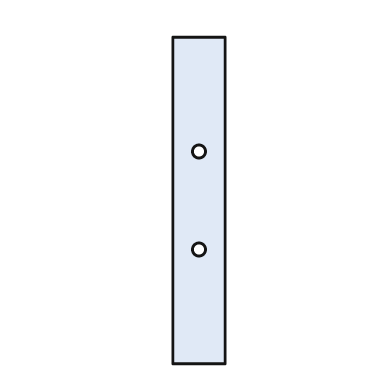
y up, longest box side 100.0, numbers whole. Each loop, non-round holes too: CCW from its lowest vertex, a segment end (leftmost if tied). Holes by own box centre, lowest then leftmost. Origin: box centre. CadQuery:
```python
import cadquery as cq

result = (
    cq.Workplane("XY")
    .moveTo(-8.0, -50.0)
    .lineTo(8.0, -50.0)
    .lineTo(8.0, 50.0)
    .lineTo(-8.0, 50.0)
    .close()
    .moveTo(0.0, -15.0)
    .circle(2.0)
    .moveTo(0.0, 15.0)
    .circle(2.0)
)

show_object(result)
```